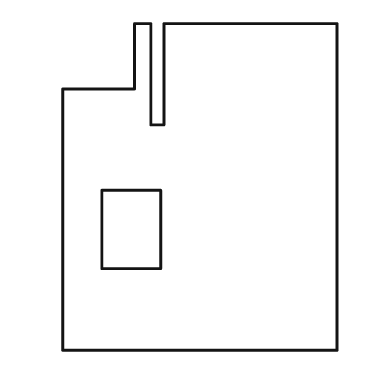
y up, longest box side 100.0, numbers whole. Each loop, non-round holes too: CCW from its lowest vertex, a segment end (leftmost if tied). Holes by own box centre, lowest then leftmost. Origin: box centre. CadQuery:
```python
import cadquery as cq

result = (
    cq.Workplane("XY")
    .moveTo(-42.0, -50.0)
    .lineTo(42.0, -50.0)
    .lineTo(42.0, 50.0)
    .lineTo(-11.0, 50.0)
    .lineTo(-11.0, 19.0)
    .lineTo(-15.0, 19.0)
    .lineTo(-15.0, 50.0)
    .lineTo(-20.0, 50.0)
    .lineTo(-20.0, 30.0)
    .lineTo(-42.0, 30.0)
    .close()
    .moveTo(-30.0, -25.0)
    .lineTo(-12.0, -25.0)
    .lineTo(-12.0, -1.0)
    .lineTo(-30.0, -1.0)
    .close()
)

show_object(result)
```